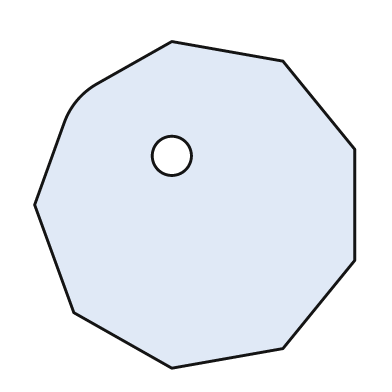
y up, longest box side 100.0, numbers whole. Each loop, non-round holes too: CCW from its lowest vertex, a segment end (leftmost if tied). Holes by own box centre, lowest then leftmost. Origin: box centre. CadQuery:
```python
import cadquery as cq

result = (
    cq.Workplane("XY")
    .moveTo(-7.0, -50.0)
    .lineTo(27.0, -44.0)
    .lineTo(49.0, -17.0)
    .lineTo(49.0, 17.0)
    .lineTo(27.0, 44.0)
    .lineTo(-7.0, 50.0)
    .lineTo(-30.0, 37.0)
    .threePointArc((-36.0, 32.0), (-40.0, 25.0))
    .lineTo(-49.0, 0.0)
    .lineTo(-37.0, -33.0)
    .close()
    .moveTo(-7.0, 15.0)
    .circle(6.0)
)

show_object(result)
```